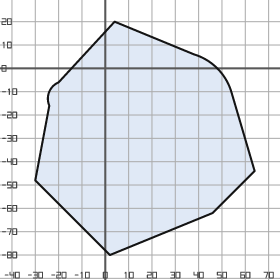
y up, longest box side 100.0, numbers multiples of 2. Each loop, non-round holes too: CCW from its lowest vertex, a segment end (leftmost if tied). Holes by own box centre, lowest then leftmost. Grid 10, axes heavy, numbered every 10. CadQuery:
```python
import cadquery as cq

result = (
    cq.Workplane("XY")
    .moveTo(2.0, -80.0)
    .lineTo(46.0, -62.0)
    .lineTo(64.0, -44.0)
    .lineTo(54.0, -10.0)
    .threePointArc((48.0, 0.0), (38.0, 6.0))
    .lineTo(4.0, 20.0)
    .lineTo(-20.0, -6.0)
    .threePointArc((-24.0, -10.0), (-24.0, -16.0))
    .lineTo(-30.0, -48.0)
    .close()
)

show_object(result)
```